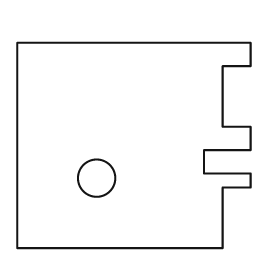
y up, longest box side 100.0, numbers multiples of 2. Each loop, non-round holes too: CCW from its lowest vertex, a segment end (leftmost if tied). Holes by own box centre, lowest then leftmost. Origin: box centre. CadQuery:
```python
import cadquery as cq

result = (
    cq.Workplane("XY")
    .moveTo(-50.0, -44.0)
    .lineTo(38.0, -44.0)
    .lineTo(38.0, -18.0)
    .lineTo(50.0, -18.0)
    .lineTo(50.0, -12.0)
    .lineTo(30.0, -12.0)
    .lineTo(30.0, -2.0)
    .lineTo(50.0, -2.0)
    .lineTo(50.0, 8.0)
    .lineTo(38.0, 8.0)
    .lineTo(38.0, 34.0)
    .lineTo(50.0, 34.0)
    .lineTo(50.0, 44.0)
    .lineTo(-50.0, 44.0)
    .close()
    .moveTo(-16.0, -14.0)
    .circle(8.0)
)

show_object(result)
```